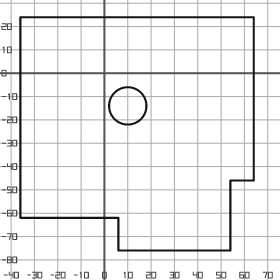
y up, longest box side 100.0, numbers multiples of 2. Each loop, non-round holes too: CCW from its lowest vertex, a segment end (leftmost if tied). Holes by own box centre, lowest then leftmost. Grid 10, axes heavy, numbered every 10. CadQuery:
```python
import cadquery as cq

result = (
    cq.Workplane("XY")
    .moveTo(6.0, -76.0)
    .lineTo(54.0, -76.0)
    .lineTo(54.0, -46.0)
    .lineTo(64.0, -46.0)
    .lineTo(64.0, 24.0)
    .lineTo(-36.0, 24.0)
    .lineTo(-36.0, -62.0)
    .lineTo(6.0, -62.0)
    .close()
    .moveTo(10.0, -14.0)
    .circle(8.0)
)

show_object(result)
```